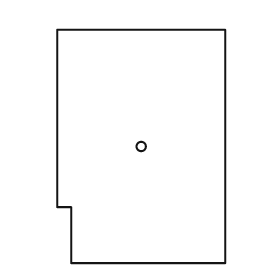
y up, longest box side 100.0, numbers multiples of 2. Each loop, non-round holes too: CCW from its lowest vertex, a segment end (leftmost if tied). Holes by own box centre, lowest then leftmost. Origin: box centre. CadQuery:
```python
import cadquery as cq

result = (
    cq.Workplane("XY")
    .moveTo(-30.0, -50.0)
    .lineTo(36.0, -50.0)
    .lineTo(36.0, 50.0)
    .lineTo(-36.0, 50.0)
    .lineTo(-36.0, -26.0)
    .lineTo(-30.0, -26.0)
    .close()
    .moveTo(0.0, 0.0)
    .circle(2.0)
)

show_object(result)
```